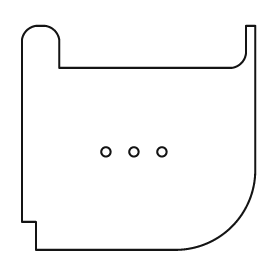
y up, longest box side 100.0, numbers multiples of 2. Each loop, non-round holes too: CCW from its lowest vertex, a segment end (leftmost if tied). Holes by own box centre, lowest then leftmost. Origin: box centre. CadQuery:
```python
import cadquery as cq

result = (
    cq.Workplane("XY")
    .moveTo(-44.0, -48.0)
    .lineTo(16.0, -48.0)
    .threePointArc((40.0, -38.0), (50.0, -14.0))
    .lineTo(50.0, 48.0)
    .lineTo(46.0, 48.0)
    .lineTo(46.0, 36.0)
    .threePointArc((44.0, 32.0), (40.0, 30.0))
    .lineTo(-34.0, 30.0)
    .lineTo(-34.0, 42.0)
    .threePointArc((-36.0, 46.0), (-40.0, 48.0))
    .lineTo(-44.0, 48.0)
    .threePointArc((-48.0, 46.0), (-50.0, 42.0))
    .lineTo(-50.0, -36.0)
    .lineTo(-44.0, -36.0)
    .close()
    .moveTo(-14.0, -6.0)
    .circle(2.0)
    .moveTo(-2.0, -6.0)
    .circle(2.0)
    .moveTo(10.0, -6.0)
    .circle(2.0)
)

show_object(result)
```